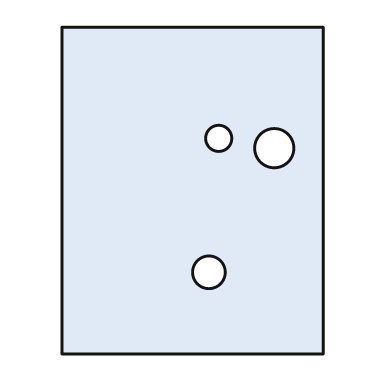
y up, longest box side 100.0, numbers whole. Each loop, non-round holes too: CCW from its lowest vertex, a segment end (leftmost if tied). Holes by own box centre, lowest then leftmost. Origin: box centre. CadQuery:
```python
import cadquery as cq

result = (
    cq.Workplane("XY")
    .moveTo(-40.0, -50.0)
    .lineTo(40.0, -50.0)
    .lineTo(40.0, 50.0)
    .lineTo(-40.0, 50.0)
    .close()
    .moveTo(5.0, -25.0)
    .circle(5.0)
    .moveTo(25.0, 13.0)
    .circle(6.0)
    .moveTo(8.0, 16.0)
    .circle(4.0)
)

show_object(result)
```